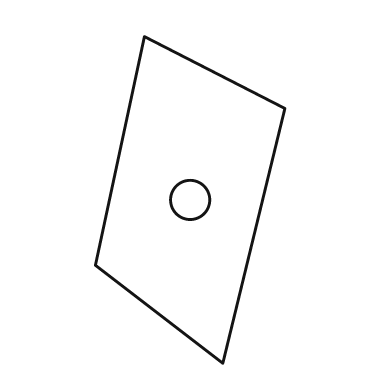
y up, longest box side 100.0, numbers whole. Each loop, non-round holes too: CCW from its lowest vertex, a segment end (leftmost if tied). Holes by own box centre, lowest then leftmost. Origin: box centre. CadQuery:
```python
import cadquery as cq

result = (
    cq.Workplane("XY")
    .moveTo(10.0, -50.0)
    .lineTo(29.0, 28.0)
    .lineTo(-14.0, 50.0)
    .lineTo(-29.0, -20.0)
    .close()
    .moveTo(0.0, 0.0)
    .circle(6.0)
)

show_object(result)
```